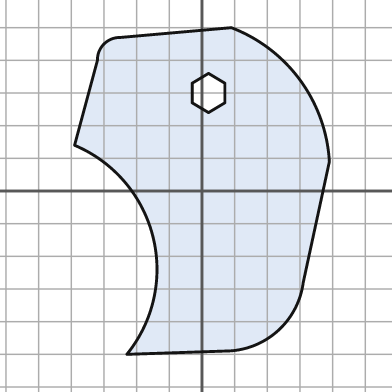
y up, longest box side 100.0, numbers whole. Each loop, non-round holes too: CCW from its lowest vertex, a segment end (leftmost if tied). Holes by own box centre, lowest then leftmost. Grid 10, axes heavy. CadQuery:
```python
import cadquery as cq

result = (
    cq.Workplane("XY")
    .moveTo(-23.0, -50.0)
    .lineTo(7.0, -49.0)
    .threePointArc((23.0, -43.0), (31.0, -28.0))
    .lineTo(39.0, 9.0)
    .threePointArc((30.0, 34.0), (9.0, 50.0))
    .lineTo(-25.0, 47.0)
    .threePointArc((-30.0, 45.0), (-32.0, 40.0))
    .lineTo(-39.0, 14.0)
    .threePointArc((-15.0, -14.0), (-23.0, -50.0))
    .close()
    .moveTo(2.0, 24.0)
    .lineTo(7.0, 27.0)
    .lineTo(7.0, 33.0)
    .lineTo(2.0, 36.0)
    .lineTo(-3.0, 33.0)
    .lineTo(-3.0, 27.0)
    .close()
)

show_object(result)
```